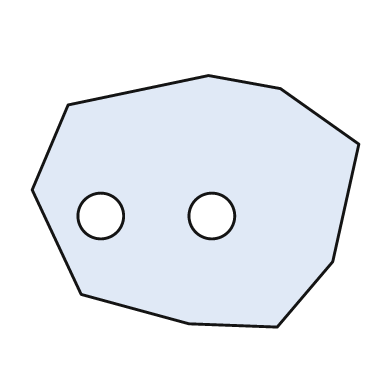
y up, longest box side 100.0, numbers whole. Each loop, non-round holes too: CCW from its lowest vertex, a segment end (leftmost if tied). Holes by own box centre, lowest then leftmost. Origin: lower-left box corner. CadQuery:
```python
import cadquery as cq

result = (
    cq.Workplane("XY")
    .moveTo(75.0, 0.0)
    .lineTo(92.0, 20.0)
    .lineTo(100.0, 56.0)
    .lineTo(76.0, 73.0)
    .lineTo(54.0, 77.0)
    .lineTo(11.0, 68.0)
    .lineTo(0.0, 42.0)
    .lineTo(15.0, 10.0)
    .lineTo(48.0, 1.0)
    .close()
    .moveTo(21.0, 34.0)
    .circle(7.0)
    .moveTo(55.0, 34.0)
    .circle(7.0)
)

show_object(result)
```